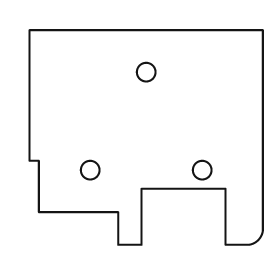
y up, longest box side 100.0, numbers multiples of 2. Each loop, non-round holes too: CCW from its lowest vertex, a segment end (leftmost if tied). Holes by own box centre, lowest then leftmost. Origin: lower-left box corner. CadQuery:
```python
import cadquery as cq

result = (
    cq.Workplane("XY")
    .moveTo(38.0, 0.0)
    .lineTo(48.0, 0.0)
    .lineTo(48.0, 24.0)
    .lineTo(84.0, 24.0)
    .lineTo(84.0, 0.0)
    .lineTo(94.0, 0.0)
    .threePointArc((98.0, 2.0), (100.0, 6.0))
    .lineTo(100.0, 92.0)
    .lineTo(0.0, 92.0)
    .lineTo(0.0, 36.0)
    .lineTo(4.0, 36.0)
    .lineTo(4.0, 14.0)
    .lineTo(38.0, 14.0)
    .close()
    .moveTo(26.0, 32.0)
    .circle(4.0)
    .moveTo(74.0, 32.0)
    .circle(4.0)
    .moveTo(50.0, 74.0)
    .circle(4.0)
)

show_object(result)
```